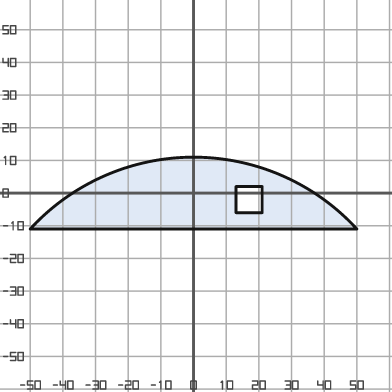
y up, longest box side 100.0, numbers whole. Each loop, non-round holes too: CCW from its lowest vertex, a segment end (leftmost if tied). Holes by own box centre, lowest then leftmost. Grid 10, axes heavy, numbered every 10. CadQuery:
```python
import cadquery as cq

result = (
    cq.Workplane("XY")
    .moveTo(-50.0, -11.0)
    .lineTo(50.0, -11.0)
    .threePointArc((0.0, 11.0), (-50.0, -11.0))
    .close()
    .moveTo(13.0, -6.0)
    .lineTo(21.0, -6.0)
    .lineTo(21.0, 2.0)
    .lineTo(13.0, 2.0)
    .close()
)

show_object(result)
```